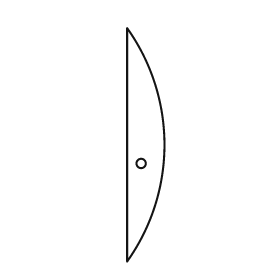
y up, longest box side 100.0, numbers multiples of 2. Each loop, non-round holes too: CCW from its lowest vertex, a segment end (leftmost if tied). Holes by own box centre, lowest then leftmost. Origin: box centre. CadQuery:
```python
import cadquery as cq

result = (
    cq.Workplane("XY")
    .moveTo(-8.0, -50.0)
    .threePointArc((8.0, 0.0), (-8.0, 50.0))
    .close()
    .moveTo(-2.0, -8.0)
    .circle(2.0)
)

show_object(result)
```